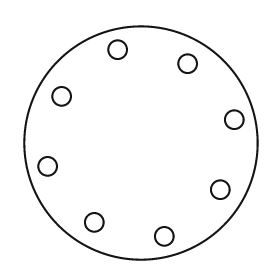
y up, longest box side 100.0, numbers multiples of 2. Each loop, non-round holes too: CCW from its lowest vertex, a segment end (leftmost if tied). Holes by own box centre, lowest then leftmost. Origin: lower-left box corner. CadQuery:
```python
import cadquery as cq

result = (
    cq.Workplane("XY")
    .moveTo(50.0, 50.0)
    .circle(50.0)
    .moveTo(60.0, 10.0)
    .circle(4.0)
    .moveTo(30.0, 16.0)
    .circle(4.0)
    .moveTo(84.0, 30.0)
    .circle(4.0)
    .moveTo(10.0, 40.0)
    .circle(4.0)
    .moveTo(90.0, 60.0)
    .circle(4.0)
    .moveTo(16.0, 70.0)
    .circle(4.0)
    .moveTo(70.0, 84.0)
    .circle(4.0)
    .moveTo(40.0, 90.0)
    .circle(4.0)
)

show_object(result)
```